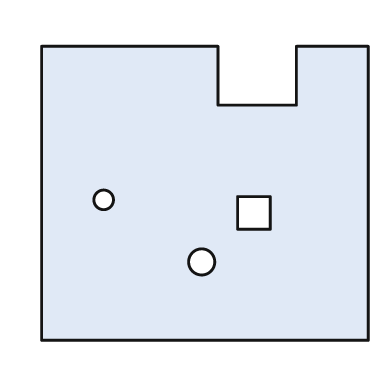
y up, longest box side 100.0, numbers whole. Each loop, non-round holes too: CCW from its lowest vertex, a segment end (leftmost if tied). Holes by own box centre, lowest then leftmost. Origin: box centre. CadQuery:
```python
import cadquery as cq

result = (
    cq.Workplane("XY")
    .moveTo(-50.0, -45.0)
    .lineTo(50.0, -45.0)
    .lineTo(50.0, 45.0)
    .lineTo(28.0, 45.0)
    .lineTo(28.0, 27.0)
    .lineTo(4.0, 27.0)
    .lineTo(4.0, 45.0)
    .lineTo(-50.0, 45.0)
    .close()
    .moveTo(-1.0, -21.0)
    .circle(4.0)
    .moveTo(10.0, -11.0)
    .lineTo(20.0, -11.0)
    .lineTo(20.0, -1.0)
    .lineTo(10.0, -1.0)
    .close()
    .moveTo(-31.0, -2.0)
    .circle(3.0)
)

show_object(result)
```